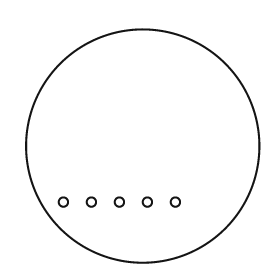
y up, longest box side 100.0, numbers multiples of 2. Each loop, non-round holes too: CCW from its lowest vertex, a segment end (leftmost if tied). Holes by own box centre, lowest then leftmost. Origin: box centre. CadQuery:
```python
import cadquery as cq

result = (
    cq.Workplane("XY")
    .moveTo(0.0, 0.0)
    .circle(50.0)
    .moveTo(-34.0, -24.0)
    .circle(2.0)
    .moveTo(-22.0, -24.0)
    .circle(2.0)
    .moveTo(-10.0, -24.0)
    .circle(2.0)
    .moveTo(2.0, -24.0)
    .circle(2.0)
    .moveTo(14.0, -24.0)
    .circle(2.0)
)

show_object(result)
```